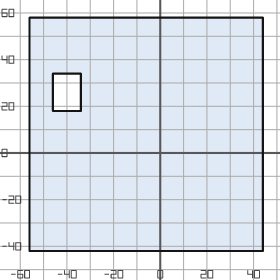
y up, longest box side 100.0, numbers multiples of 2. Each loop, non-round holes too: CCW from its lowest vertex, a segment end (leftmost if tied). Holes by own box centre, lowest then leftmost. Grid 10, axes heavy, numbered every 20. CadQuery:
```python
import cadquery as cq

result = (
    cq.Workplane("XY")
    .moveTo(-56.0, -42.0)
    .lineTo(44.0, -42.0)
    .lineTo(44.0, 58.0)
    .lineTo(-56.0, 58.0)
    .close()
    .moveTo(-46.0, 18.0)
    .lineTo(-34.0, 18.0)
    .lineTo(-34.0, 34.0)
    .lineTo(-46.0, 34.0)
    .close()
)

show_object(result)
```